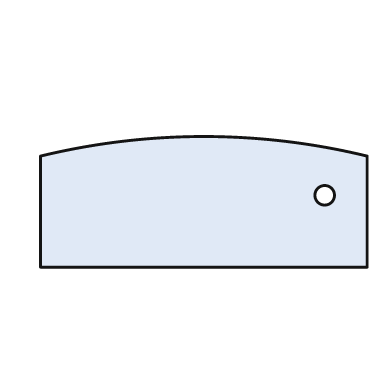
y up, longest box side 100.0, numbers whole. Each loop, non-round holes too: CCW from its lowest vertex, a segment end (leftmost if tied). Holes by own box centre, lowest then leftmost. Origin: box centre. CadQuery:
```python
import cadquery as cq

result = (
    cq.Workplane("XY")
    .moveTo(-50.0, -20.0)
    .lineTo(50.0, -20.0)
    .lineTo(50.0, 14.0)
    .threePointArc((0.0, 20.0), (-50.0, 14.0))
    .close()
    .moveTo(37.0, 2.0)
    .circle(3.0)
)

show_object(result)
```